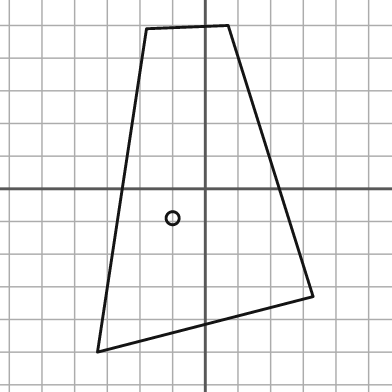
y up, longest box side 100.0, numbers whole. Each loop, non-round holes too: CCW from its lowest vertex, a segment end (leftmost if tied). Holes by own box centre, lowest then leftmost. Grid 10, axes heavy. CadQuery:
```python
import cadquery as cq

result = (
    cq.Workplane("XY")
    .moveTo(-33.0, -50.0)
    .lineTo(33.0, -33.0)
    .lineTo(7.0, 50.0)
    .lineTo(-18.0, 49.0)
    .close()
    .moveTo(-10.0, -9.0)
    .circle(2.0)
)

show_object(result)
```